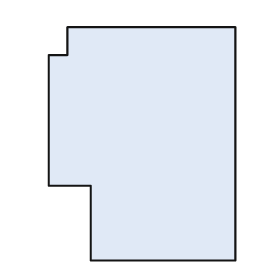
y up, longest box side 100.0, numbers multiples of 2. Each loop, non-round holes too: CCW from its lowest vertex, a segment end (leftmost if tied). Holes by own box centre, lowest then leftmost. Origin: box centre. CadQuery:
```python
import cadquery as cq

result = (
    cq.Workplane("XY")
    .moveTo(-22.0, -50.0)
    .lineTo(40.0, -50.0)
    .lineTo(40.0, 50.0)
    .lineTo(-32.0, 50.0)
    .lineTo(-32.0, 38.0)
    .lineTo(-40.0, 38.0)
    .lineTo(-40.0, -18.0)
    .lineTo(-22.0, -18.0)
    .close()
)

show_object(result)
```